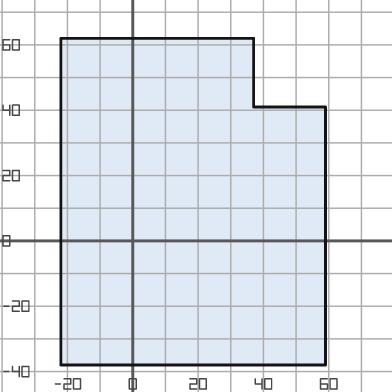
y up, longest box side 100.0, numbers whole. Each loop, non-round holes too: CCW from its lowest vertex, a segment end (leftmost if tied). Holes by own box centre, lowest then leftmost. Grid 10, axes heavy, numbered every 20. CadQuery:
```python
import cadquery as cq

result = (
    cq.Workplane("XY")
    .moveTo(-22.0, -38.0)
    .lineTo(59.0, -38.0)
    .lineTo(59.0, 41.0)
    .lineTo(37.0, 41.0)
    .lineTo(37.0, 62.0)
    .lineTo(-22.0, 62.0)
    .close()
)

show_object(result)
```